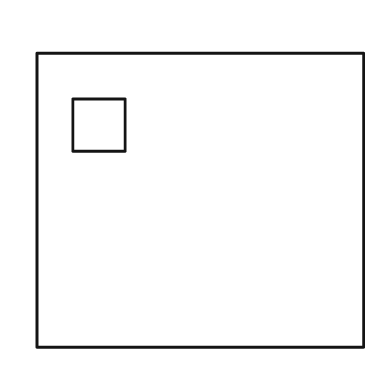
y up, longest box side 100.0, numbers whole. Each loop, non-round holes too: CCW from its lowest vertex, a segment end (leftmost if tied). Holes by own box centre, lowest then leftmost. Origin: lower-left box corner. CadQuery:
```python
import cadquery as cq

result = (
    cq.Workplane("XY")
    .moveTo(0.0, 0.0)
    .lineTo(100.0, 0.0)
    .lineTo(100.0, 90.0)
    .lineTo(0.0, 90.0)
    .close()
    .moveTo(11.0, 60.0)
    .lineTo(27.0, 60.0)
    .lineTo(27.0, 76.0)
    .lineTo(11.0, 76.0)
    .close()
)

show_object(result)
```